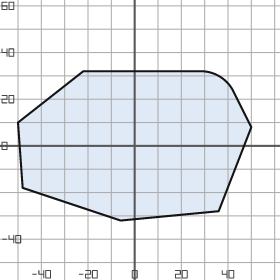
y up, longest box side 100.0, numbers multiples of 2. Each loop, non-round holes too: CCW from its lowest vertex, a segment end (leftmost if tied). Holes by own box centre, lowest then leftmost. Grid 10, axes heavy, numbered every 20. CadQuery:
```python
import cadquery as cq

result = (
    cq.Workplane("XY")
    .moveTo(-6.0, -32.0)
    .lineTo(36.0, -28.0)
    .lineTo(50.0, 8.0)
    .lineTo(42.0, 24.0)
    .threePointArc((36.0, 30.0), (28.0, 32.0))
    .lineTo(-22.0, 32.0)
    .lineTo(-50.0, 10.0)
    .lineTo(-48.0, -18.0)
    .close()
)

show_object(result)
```